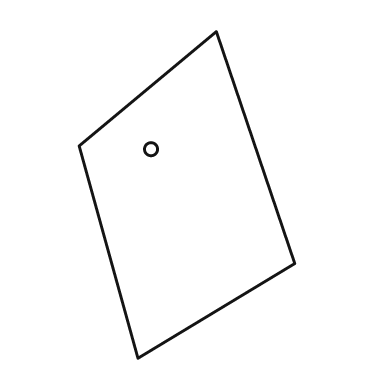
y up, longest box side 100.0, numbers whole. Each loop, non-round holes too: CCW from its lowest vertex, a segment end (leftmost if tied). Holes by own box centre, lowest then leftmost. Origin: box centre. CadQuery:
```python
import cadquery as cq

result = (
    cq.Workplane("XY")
    .moveTo(-15.0, -50.0)
    .lineTo(33.0, -21.0)
    .lineTo(9.0, 50.0)
    .lineTo(-33.0, 15.0)
    .close()
    .moveTo(-11.0, 14.0)
    .circle(2.0)
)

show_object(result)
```